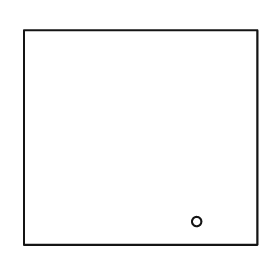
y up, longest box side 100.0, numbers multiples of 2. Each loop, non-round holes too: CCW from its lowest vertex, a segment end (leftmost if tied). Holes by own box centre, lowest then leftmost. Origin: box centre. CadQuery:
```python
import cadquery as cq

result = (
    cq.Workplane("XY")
    .moveTo(-50.0, -46.0)
    .lineTo(50.0, -46.0)
    .lineTo(50.0, 46.0)
    .lineTo(-50.0, 46.0)
    .close()
    .moveTo(24.0, -36.0)
    .circle(2.0)
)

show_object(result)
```